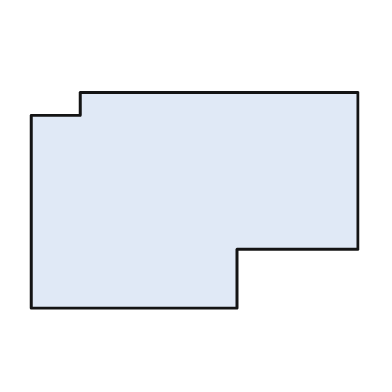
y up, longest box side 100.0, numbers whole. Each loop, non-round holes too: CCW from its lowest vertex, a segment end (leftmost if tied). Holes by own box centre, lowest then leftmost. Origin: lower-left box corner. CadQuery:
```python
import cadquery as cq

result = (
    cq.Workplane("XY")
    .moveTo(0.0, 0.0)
    .lineTo(63.0, 0.0)
    .lineTo(63.0, 18.0)
    .lineTo(100.0, 18.0)
    .lineTo(100.0, 66.0)
    .lineTo(15.0, 66.0)
    .lineTo(15.0, 59.0)
    .lineTo(0.0, 59.0)
    .close()
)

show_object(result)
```